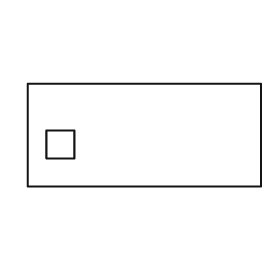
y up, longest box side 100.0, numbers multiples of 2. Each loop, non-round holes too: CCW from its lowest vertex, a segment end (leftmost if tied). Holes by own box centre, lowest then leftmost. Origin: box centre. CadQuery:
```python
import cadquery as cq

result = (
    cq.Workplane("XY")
    .moveTo(-50.0, -22.0)
    .lineTo(50.0, -22.0)
    .lineTo(50.0, 22.0)
    .lineTo(-50.0, 22.0)
    .close()
    .moveTo(-42.0, -10.0)
    .lineTo(-30.0, -10.0)
    .lineTo(-30.0, 2.0)
    .lineTo(-42.0, 2.0)
    .close()
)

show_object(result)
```